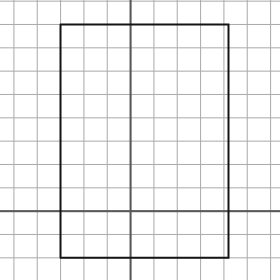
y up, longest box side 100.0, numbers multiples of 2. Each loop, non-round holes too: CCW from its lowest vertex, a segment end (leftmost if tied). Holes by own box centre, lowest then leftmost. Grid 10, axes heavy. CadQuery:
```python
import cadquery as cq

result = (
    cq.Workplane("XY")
    .moveTo(-30.0, -20.0)
    .lineTo(42.0, -20.0)
    .lineTo(42.0, 80.0)
    .lineTo(-30.0, 80.0)
    .close()
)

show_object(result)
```